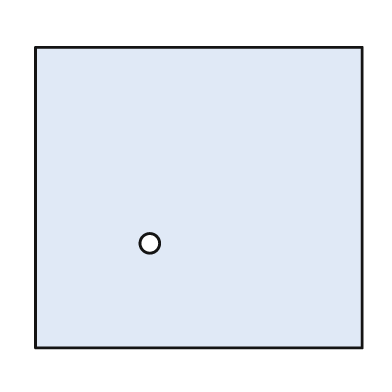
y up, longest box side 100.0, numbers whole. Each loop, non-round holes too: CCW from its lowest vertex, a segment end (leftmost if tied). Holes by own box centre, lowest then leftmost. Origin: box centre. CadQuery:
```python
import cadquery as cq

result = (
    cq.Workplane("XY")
    .moveTo(-50.0, -46.0)
    .lineTo(50.0, -46.0)
    .lineTo(50.0, 46.0)
    .lineTo(-50.0, 46.0)
    .close()
    .moveTo(-15.0, -14.0)
    .circle(3.0)
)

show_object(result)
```